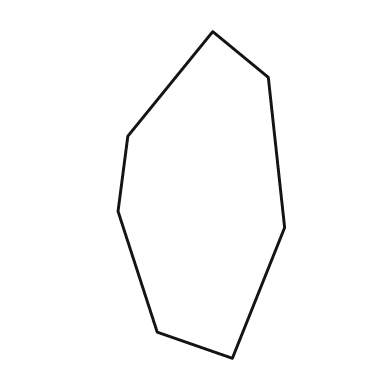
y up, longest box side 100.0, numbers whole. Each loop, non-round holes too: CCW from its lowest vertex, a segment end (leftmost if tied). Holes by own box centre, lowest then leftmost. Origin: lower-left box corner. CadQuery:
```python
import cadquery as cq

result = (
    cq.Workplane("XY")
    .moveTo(35.0, 0.0)
    .lineTo(51.0, 40.0)
    .lineTo(46.0, 86.0)
    .lineTo(29.0, 100.0)
    .lineTo(3.0, 68.0)
    .lineTo(0.0, 45.0)
    .lineTo(12.0, 8.0)
    .close()
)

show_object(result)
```